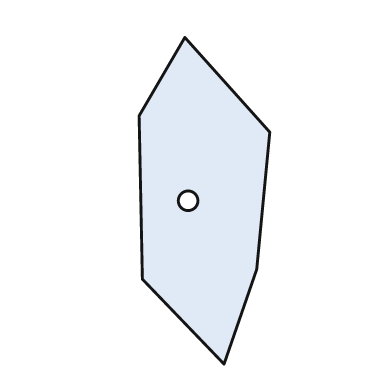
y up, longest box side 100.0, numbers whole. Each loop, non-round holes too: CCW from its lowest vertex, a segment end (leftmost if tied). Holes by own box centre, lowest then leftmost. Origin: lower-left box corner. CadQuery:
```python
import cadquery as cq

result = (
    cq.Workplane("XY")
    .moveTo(26.0, 0.0)
    .lineTo(36.0, 29.0)
    .lineTo(40.0, 71.0)
    .lineTo(14.0, 100.0)
    .lineTo(0.0, 76.0)
    .lineTo(1.0, 26.0)
    .close()
    .moveTo(15.0, 50.0)
    .circle(3.0)
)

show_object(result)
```